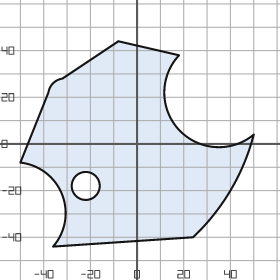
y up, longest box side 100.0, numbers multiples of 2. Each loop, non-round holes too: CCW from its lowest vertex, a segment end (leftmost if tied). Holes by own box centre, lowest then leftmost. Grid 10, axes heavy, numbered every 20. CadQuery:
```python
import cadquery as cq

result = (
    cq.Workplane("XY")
    .moveTo(-36.0, -44.0)
    .lineTo(24.0, -40.0)
    .threePointArc((40.0, -20.0), (50.0, 4.0))
    .threePointArc((18.0, 6.0), (18.0, 38.0))
    .lineTo(-8.0, 44.0)
    .lineTo(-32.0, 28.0)
    .threePointArc((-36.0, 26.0), (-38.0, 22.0))
    .lineTo(-50.0, -8.0)
    .threePointArc((-32.0, -22.0), (-36.0, -44.0))
    .close()
    .moveTo(-22.0, -18.0)
    .circle(6.0)
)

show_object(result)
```